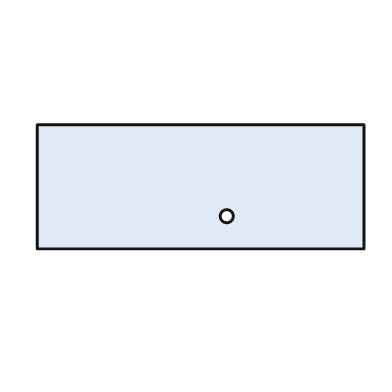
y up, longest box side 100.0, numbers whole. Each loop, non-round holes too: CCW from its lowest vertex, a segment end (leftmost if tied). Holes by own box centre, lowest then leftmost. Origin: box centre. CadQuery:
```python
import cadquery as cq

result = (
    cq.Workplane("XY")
    .moveTo(-50.0, -19.0)
    .lineTo(50.0, -19.0)
    .lineTo(50.0, 19.0)
    .lineTo(-50.0, 19.0)
    .close()
    .moveTo(8.0, -9.0)
    .circle(2.0)
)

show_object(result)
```